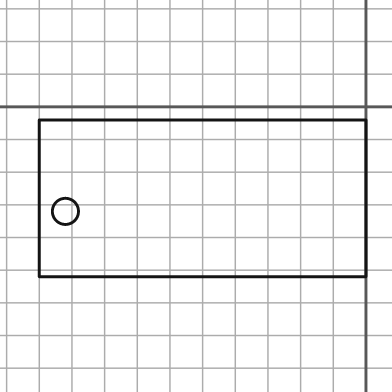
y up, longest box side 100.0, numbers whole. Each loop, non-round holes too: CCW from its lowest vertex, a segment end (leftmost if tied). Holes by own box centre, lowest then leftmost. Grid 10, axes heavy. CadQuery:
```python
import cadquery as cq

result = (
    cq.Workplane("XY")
    .moveTo(-100.0, -52.0)
    .lineTo(0.0, -52.0)
    .lineTo(0.0, -4.0)
    .lineTo(-100.0, -4.0)
    .close()
    .moveTo(-92.0, -32.0)
    .circle(4.0)
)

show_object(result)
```